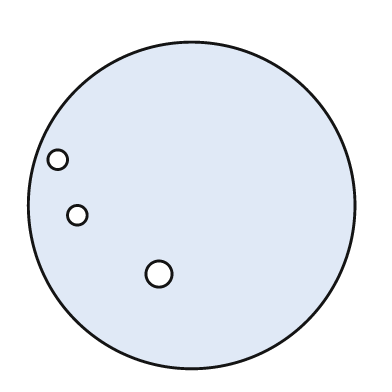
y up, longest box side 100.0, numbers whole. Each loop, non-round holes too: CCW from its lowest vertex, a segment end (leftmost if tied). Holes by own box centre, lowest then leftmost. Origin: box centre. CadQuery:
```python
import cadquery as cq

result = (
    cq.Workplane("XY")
    .moveTo(0.0, 0.0)
    .circle(50.0)
    .moveTo(-10.0, -21.0)
    .circle(4.0)
    .moveTo(-35.0, -3.0)
    .circle(3.0)
    .moveTo(-41.0, 14.0)
    .circle(3.0)
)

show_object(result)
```